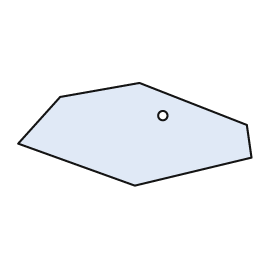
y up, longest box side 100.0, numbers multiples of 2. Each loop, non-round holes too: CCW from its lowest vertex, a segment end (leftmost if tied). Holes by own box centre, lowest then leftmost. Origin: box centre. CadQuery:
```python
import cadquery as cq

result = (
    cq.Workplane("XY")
    .moveTo(0.0, -22.0)
    .lineTo(50.0, -10.0)
    .lineTo(48.0, 4.0)
    .lineTo(2.0, 22.0)
    .lineTo(-32.0, 16.0)
    .lineTo(-50.0, -4.0)
    .close()
    .moveTo(12.0, 8.0)
    .circle(2.0)
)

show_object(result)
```